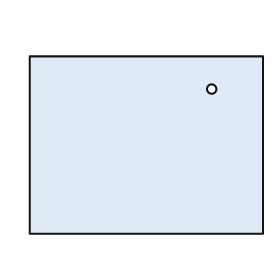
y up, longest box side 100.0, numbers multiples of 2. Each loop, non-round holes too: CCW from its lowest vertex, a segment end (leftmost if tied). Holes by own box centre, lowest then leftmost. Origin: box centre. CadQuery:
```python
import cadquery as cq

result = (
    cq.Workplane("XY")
    .moveTo(-50.0, -38.0)
    .lineTo(50.0, -38.0)
    .lineTo(50.0, 38.0)
    .lineTo(-50.0, 38.0)
    .close()
    .moveTo(28.0, 24.0)
    .circle(2.0)
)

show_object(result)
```